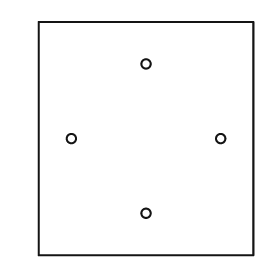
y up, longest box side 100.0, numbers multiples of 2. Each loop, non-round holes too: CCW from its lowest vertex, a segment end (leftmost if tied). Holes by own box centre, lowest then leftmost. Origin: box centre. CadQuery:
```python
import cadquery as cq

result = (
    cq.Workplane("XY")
    .moveTo(-46.0, -50.0)
    .lineTo(46.0, -50.0)
    .lineTo(46.0, 50.0)
    .lineTo(-46.0, 50.0)
    .close()
    .moveTo(0.0, -32.0)
    .circle(2.0)
    .moveTo(-32.0, 0.0)
    .circle(2.0)
    .moveTo(32.0, 0.0)
    .circle(2.0)
    .moveTo(0.0, 32.0)
    .circle(2.0)
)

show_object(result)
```